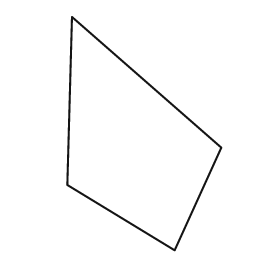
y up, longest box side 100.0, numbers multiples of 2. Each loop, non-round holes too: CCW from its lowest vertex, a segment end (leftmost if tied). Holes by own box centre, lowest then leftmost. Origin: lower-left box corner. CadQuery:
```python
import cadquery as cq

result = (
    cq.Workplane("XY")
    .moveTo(46.0, 0.0)
    .lineTo(66.0, 44.0)
    .lineTo(2.0, 100.0)
    .lineTo(0.0, 28.0)
    .close()
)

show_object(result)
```